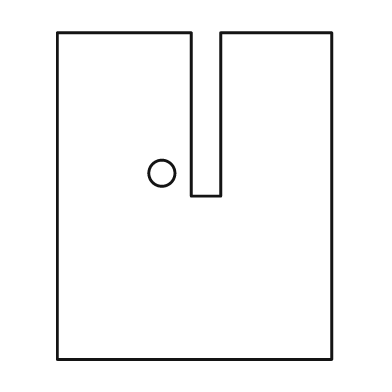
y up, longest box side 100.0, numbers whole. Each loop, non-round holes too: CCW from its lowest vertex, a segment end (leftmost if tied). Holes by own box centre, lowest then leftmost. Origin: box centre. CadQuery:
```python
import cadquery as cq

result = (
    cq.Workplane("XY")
    .moveTo(-42.0, -50.0)
    .lineTo(42.0, -50.0)
    .lineTo(42.0, 50.0)
    .lineTo(8.0, 50.0)
    .lineTo(8.0, 0.0)
    .lineTo(-1.0, 0.0)
    .lineTo(-1.0, 50.0)
    .lineTo(-42.0, 50.0)
    .close()
    .moveTo(-10.0, 7.0)
    .circle(4.0)
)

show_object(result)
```